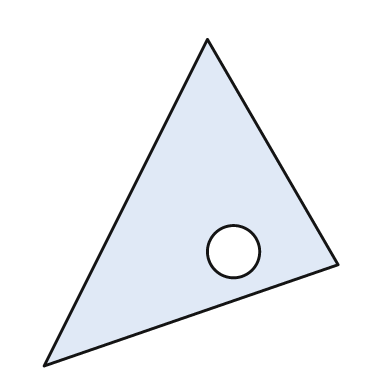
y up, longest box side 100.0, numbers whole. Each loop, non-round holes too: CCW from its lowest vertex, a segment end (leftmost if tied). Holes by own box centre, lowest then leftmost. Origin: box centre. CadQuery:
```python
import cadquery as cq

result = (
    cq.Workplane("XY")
    .moveTo(-45.0, -50.0)
    .lineTo(45.0, -19.0)
    .lineTo(5.0, 50.0)
    .close()
    .moveTo(13.0, -15.0)
    .circle(8.0)
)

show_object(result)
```